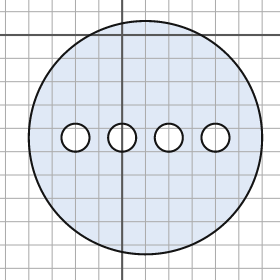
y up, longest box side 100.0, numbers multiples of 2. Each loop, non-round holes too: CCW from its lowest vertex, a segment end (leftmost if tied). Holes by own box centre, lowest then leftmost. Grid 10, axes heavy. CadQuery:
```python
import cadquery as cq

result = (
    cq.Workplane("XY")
    .moveTo(10.0, -44.0)
    .circle(50.0)
    .moveTo(-20.0, -44.0)
    .circle(6.0)
    .moveTo(0.0, -44.0)
    .circle(6.0)
    .moveTo(20.0, -44.0)
    .circle(6.0)
    .moveTo(40.0, -44.0)
    .circle(6.0)
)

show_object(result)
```